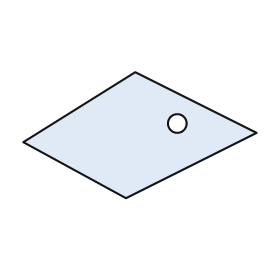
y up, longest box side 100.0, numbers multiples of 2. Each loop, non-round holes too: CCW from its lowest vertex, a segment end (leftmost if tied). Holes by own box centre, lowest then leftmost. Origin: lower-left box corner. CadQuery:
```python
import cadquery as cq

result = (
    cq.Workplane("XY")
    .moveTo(44.0, 0.0)
    .lineTo(100.0, 28.0)
    .lineTo(48.0, 54.0)
    .lineTo(0.0, 24.0)
    .close()
    .moveTo(66.0, 32.0)
    .circle(4.0)
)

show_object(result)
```